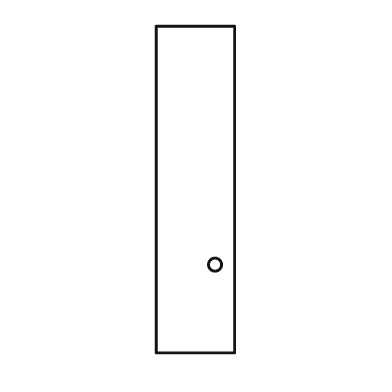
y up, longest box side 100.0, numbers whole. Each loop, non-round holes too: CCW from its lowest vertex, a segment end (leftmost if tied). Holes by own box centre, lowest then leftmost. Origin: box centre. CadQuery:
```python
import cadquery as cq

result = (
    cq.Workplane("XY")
    .moveTo(-12.0, -50.0)
    .lineTo(12.0, -50.0)
    .lineTo(12.0, 50.0)
    .lineTo(-12.0, 50.0)
    .close()
    .moveTo(6.0, -23.0)
    .circle(2.0)
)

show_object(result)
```